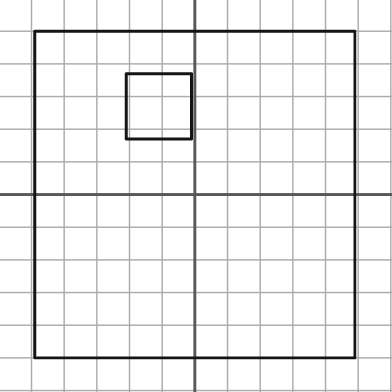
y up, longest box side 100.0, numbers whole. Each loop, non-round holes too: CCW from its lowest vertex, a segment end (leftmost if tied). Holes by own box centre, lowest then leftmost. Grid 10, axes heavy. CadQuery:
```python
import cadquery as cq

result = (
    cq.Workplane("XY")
    .moveTo(-49.0, -50.0)
    .lineTo(49.0, -50.0)
    .lineTo(49.0, 50.0)
    .lineTo(-49.0, 50.0)
    .close()
    .moveTo(-21.0, 17.0)
    .lineTo(-1.0, 17.0)
    .lineTo(-1.0, 37.0)
    .lineTo(-21.0, 37.0)
    .close()
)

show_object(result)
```